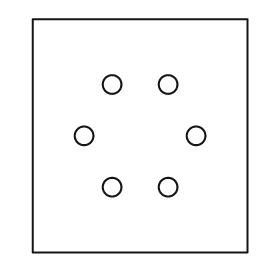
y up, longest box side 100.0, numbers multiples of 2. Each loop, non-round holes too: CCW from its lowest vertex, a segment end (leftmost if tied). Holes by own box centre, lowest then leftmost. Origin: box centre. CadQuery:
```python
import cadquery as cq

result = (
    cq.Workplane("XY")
    .moveTo(-46.0, -50.0)
    .lineTo(46.0, -50.0)
    .lineTo(46.0, 50.0)
    .lineTo(-46.0, 50.0)
    .close()
    .moveTo(-12.0, -22.0)
    .circle(4.0)
    .moveTo(12.0, -22.0)
    .circle(4.0)
    .moveTo(-24.0, 0.0)
    .circle(4.0)
    .moveTo(24.0, 0.0)
    .circle(4.0)
    .moveTo(-12.0, 22.0)
    .circle(4.0)
    .moveTo(12.0, 22.0)
    .circle(4.0)
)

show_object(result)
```